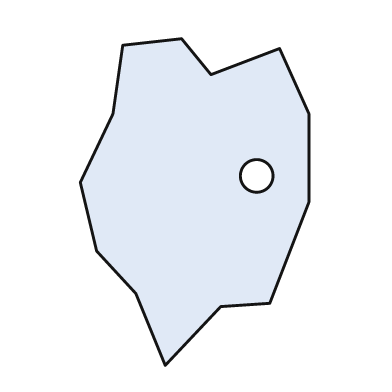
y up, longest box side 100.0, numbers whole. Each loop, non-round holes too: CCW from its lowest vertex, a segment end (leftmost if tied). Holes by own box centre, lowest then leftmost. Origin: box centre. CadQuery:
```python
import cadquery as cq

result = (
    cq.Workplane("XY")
    .moveTo(-9.0, -50.0)
    .lineTo(8.0, -32.0)
    .lineTo(23.0, -31.0)
    .lineTo(35.0, 0.0)
    .lineTo(35.0, 27.0)
    .lineTo(26.0, 47.0)
    .lineTo(5.0, 39.0)
    .lineTo(-4.0, 50.0)
    .lineTo(-22.0, 48.0)
    .lineTo(-25.0, 27.0)
    .lineTo(-35.0, 6.0)
    .lineTo(-30.0, -15.0)
    .lineTo(-18.0, -28.0)
    .close()
    .moveTo(19.0, 8.0)
    .circle(5.0)
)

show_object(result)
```